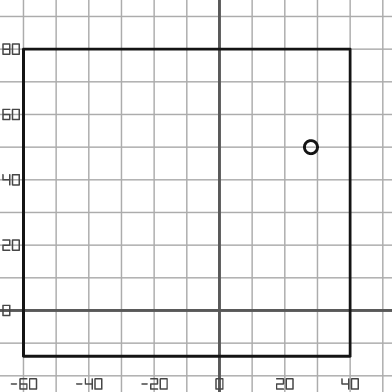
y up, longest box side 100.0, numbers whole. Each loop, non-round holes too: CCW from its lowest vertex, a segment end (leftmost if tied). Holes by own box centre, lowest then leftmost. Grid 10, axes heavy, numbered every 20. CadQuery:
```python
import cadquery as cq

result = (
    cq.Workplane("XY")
    .moveTo(-60.0, -14.0)
    .lineTo(40.0, -14.0)
    .lineTo(40.0, 80.0)
    .lineTo(-60.0, 80.0)
    .close()
    .moveTo(28.0, 50.0)
    .circle(2.0)
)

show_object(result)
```